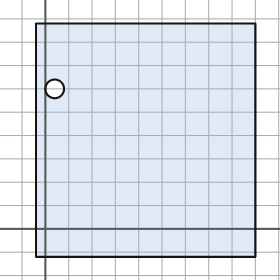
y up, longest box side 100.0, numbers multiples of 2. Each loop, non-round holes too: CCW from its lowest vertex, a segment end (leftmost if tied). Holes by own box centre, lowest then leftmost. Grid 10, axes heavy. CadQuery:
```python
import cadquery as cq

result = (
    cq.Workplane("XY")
    .moveTo(-4.0, -12.0)
    .lineTo(90.0, -12.0)
    .lineTo(90.0, 88.0)
    .lineTo(-4.0, 88.0)
    .close()
    .moveTo(4.0, 60.0)
    .circle(4.0)
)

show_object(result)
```